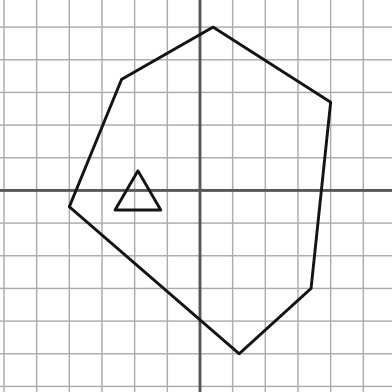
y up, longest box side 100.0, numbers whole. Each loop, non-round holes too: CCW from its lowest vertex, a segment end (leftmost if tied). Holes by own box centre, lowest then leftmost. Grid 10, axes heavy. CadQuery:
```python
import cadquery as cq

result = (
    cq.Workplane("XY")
    .moveTo(12.0, -50.0)
    .lineTo(34.0, -30.0)
    .lineTo(40.0, 27.0)
    .lineTo(4.0, 50.0)
    .lineTo(-24.0, 34.0)
    .lineTo(-40.0, -5.0)
    .close()
    .moveTo(-26.0, -6.0)
    .lineTo(-12.0, -6.0)
    .lineTo(-19.0, 6.0)
    .close()
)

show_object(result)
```